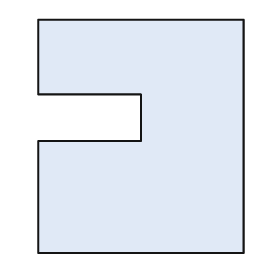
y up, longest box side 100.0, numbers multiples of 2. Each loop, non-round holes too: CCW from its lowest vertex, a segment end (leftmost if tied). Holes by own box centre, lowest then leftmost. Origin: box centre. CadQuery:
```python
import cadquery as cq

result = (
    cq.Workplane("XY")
    .moveTo(-44.0, -50.0)
    .lineTo(44.0, -50.0)
    .lineTo(44.0, 50.0)
    .lineTo(-44.0, 50.0)
    .lineTo(-44.0, 18.0)
    .lineTo(0.0, 18.0)
    .lineTo(0.0, -2.0)
    .lineTo(-44.0, -2.0)
    .close()
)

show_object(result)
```